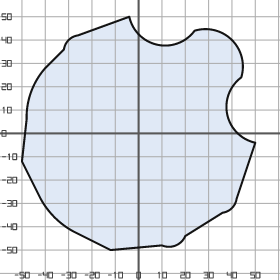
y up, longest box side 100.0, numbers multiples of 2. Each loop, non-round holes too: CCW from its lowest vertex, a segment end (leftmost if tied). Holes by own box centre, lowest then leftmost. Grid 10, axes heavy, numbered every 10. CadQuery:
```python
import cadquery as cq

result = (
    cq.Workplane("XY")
    .moveTo(-12.0, -50.0)
    .lineTo(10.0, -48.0)
    .threePointArc((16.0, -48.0), (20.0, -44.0))
    .lineTo(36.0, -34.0)
    .threePointArc((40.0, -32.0), (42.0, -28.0))
    .lineTo(50.0, -4.0)
    .threePointArc((38.0, 8.0), (44.0, 24.0))
    .threePointArc((40.0, 40.0), (24.0, 44.0))
    .threePointArc((8.0, 38.0), (-4.0, 50.0))
    .lineTo(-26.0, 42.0)
    .threePointArc((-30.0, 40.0), (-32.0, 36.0))
    .lineTo(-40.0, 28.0)
    .threePointArc((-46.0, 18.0), (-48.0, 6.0))
    .lineTo(-50.0, -12.0)
    .lineTo(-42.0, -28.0)
    .threePointArc((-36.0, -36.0), (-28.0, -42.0))
    .close()
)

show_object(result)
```